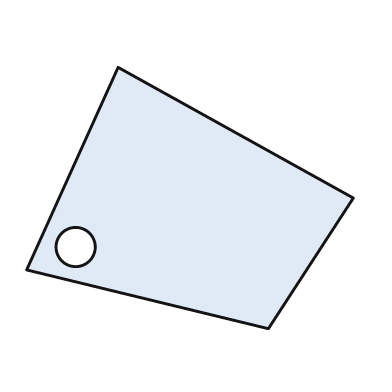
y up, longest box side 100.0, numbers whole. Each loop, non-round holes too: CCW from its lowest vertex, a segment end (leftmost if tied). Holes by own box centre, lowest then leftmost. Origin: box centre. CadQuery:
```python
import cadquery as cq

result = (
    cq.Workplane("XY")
    .moveTo(24.0, -40.0)
    .lineTo(50.0, 0.0)
    .lineTo(-22.0, 40.0)
    .lineTo(-50.0, -22.0)
    .close()
    .moveTo(-35.0, -15.0)
    .circle(6.0)
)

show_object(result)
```